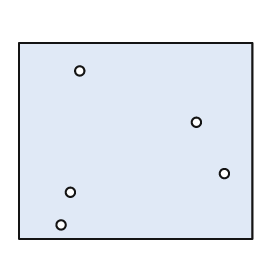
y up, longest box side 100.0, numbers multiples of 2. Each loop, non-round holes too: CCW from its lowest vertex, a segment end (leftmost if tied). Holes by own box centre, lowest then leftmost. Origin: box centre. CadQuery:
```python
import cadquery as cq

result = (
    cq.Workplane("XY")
    .moveTo(-50.0, -42.0)
    .lineTo(50.0, -42.0)
    .lineTo(50.0, 42.0)
    .lineTo(-50.0, 42.0)
    .close()
    .moveTo(-32.0, -36.0)
    .circle(2.0)
    .moveTo(-28.0, -22.0)
    .circle(2.0)
    .moveTo(38.0, -14.0)
    .circle(2.0)
    .moveTo(26.0, 8.0)
    .circle(2.0)
    .moveTo(-24.0, 30.0)
    .circle(2.0)
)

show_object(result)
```